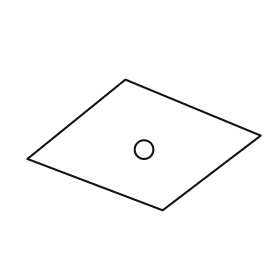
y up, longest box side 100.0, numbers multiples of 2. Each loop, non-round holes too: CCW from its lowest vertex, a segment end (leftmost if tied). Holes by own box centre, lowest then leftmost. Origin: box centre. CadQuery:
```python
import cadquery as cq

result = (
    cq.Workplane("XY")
    .moveTo(8.0, -28.0)
    .lineTo(50.0, 4.0)
    .lineTo(-8.0, 28.0)
    .lineTo(-50.0, -6.0)
    .close()
    .moveTo(0.0, -2.0)
    .circle(4.0)
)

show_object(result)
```